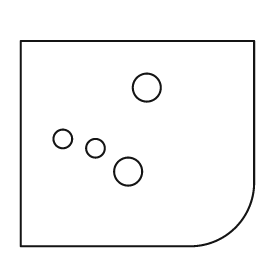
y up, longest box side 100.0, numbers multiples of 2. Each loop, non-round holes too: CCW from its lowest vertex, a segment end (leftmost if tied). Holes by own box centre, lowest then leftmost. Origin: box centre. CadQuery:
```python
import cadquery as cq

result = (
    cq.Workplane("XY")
    .moveTo(-50.0, -44.0)
    .lineTo(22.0, -44.0)
    .threePointArc((42.0, -36.0), (50.0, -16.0))
    .lineTo(50.0, 44.0)
    .lineTo(-50.0, 44.0)
    .close()
    .moveTo(-4.0, -12.0)
    .circle(6.0)
    .moveTo(-18.0, -2.0)
    .circle(4.0)
    .moveTo(-32.0, 2.0)
    .circle(4.0)
    .moveTo(4.0, 24.0)
    .circle(6.0)
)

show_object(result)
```